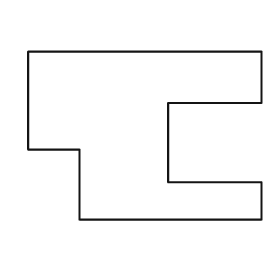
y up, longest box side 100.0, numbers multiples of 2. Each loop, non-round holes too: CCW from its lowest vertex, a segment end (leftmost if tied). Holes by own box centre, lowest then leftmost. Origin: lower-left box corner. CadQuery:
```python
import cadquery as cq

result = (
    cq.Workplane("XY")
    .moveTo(22.0, 0.0)
    .lineTo(100.0, 0.0)
    .lineTo(100.0, 16.0)
    .lineTo(60.0, 16.0)
    .lineTo(60.0, 50.0)
    .lineTo(100.0, 50.0)
    .lineTo(100.0, 72.0)
    .lineTo(0.0, 72.0)
    .lineTo(0.0, 30.0)
    .lineTo(22.0, 30.0)
    .close()
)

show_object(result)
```